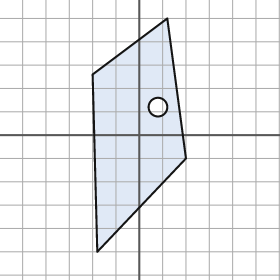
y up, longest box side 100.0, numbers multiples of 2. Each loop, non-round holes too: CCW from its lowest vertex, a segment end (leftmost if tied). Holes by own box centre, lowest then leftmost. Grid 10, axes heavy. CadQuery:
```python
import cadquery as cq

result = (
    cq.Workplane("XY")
    .moveTo(-18.0, -50.0)
    .lineTo(20.0, -10.0)
    .lineTo(12.0, 50.0)
    .lineTo(-20.0, 26.0)
    .close()
    .moveTo(8.0, 12.0)
    .circle(4.0)
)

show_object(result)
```